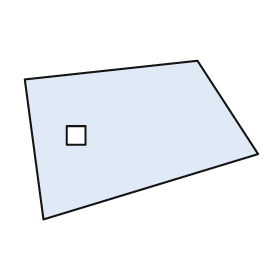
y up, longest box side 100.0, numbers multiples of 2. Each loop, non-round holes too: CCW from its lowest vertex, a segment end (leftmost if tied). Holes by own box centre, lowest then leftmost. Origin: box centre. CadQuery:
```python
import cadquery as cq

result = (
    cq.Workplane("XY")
    .moveTo(-42.0, -34.0)
    .lineTo(50.0, -6.0)
    .lineTo(24.0, 34.0)
    .lineTo(-50.0, 26.0)
    .close()
    .moveTo(-32.0, -2.0)
    .lineTo(-24.0, -2.0)
    .lineTo(-24.0, 6.0)
    .lineTo(-32.0, 6.0)
    .close()
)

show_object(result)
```